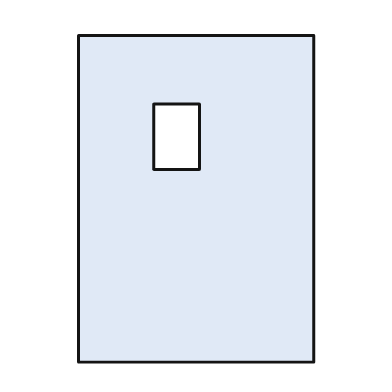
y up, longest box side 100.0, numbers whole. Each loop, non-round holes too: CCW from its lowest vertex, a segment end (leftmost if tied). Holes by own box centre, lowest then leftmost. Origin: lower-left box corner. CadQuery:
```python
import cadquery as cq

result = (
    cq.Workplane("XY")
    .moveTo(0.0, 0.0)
    .lineTo(72.0, 0.0)
    .lineTo(72.0, 100.0)
    .lineTo(0.0, 100.0)
    .close()
    .moveTo(23.0, 59.0)
    .lineTo(37.0, 59.0)
    .lineTo(37.0, 79.0)
    .lineTo(23.0, 79.0)
    .close()
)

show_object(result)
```